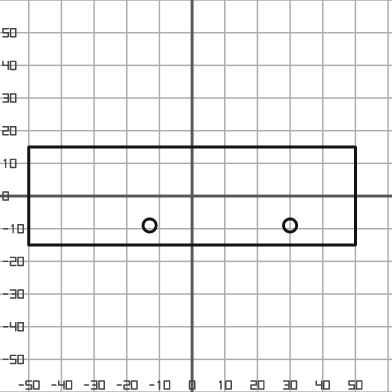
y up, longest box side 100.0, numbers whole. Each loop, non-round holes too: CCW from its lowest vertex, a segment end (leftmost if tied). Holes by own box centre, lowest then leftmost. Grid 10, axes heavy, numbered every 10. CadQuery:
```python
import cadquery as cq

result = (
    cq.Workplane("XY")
    .moveTo(-50.0, -15.0)
    .lineTo(50.0, -15.0)
    .lineTo(50.0, 15.0)
    .lineTo(-50.0, 15.0)
    .close()
    .moveTo(-13.0, -9.0)
    .circle(2.0)
    .moveTo(30.0, -9.0)
    .circle(2.0)
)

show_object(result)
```